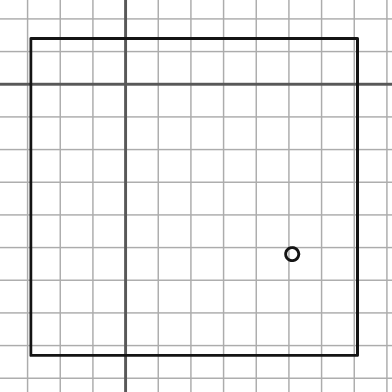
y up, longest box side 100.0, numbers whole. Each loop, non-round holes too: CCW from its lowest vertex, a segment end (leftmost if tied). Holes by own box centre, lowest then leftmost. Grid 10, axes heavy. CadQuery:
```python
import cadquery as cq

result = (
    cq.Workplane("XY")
    .moveTo(-29.0, -83.0)
    .lineTo(71.0, -83.0)
    .lineTo(71.0, 14.0)
    .lineTo(-29.0, 14.0)
    .close()
    .moveTo(51.0, -52.0)
    .circle(2.0)
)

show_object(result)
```